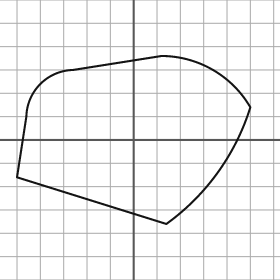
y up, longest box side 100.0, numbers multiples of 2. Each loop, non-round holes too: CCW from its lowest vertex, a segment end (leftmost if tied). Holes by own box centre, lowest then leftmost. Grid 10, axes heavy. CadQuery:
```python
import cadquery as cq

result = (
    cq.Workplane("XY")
    .moveTo(14.0, -36.0)
    .threePointArc((36.0, -14.0), (50.0, 14.0))
    .threePointArc((34.0, 30.0), (12.0, 36.0))
    .lineTo(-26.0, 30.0)
    .threePointArc((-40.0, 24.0), (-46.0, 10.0))
    .lineTo(-50.0, -16.0)
    .close()
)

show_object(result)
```